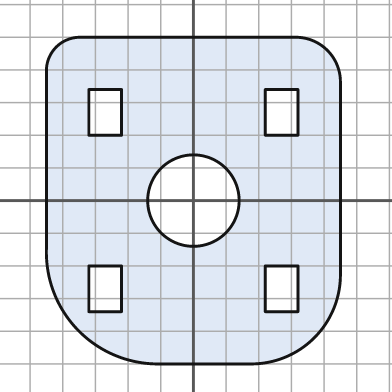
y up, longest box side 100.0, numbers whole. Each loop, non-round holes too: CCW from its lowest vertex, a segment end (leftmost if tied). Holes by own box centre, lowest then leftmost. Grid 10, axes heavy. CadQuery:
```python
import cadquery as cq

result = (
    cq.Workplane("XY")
    .moveTo(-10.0, -50.0)
    .lineTo(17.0, -50.0)
    .threePointArc((37.0, -42.0), (45.0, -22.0))
    .lineTo(45.0, 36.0)
    .threePointArc((41.0, 46.0), (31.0, 50.0))
    .lineTo(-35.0, 50.0)
    .threePointArc((-42.0, 47.0), (-45.0, 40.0))
    .lineTo(-45.0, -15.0)
    .threePointArc((-35.0, -40.0), (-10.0, -50.0))
    .close()
    .moveTo(-32.0, -34.0)
    .lineTo(-22.0, -34.0)
    .lineTo(-22.0, -20.0)
    .lineTo(-32.0, -20.0)
    .close()
    .moveTo(22.0, -34.0)
    .lineTo(32.0, -34.0)
    .lineTo(32.0, -20.0)
    .lineTo(22.0, -20.0)
    .close()
    .moveTo(0.0, 0.0)
    .circle(14.0)
    .moveTo(-32.0, 20.0)
    .lineTo(-22.0, 20.0)
    .lineTo(-22.0, 34.0)
    .lineTo(-32.0, 34.0)
    .close()
    .moveTo(22.0, 20.0)
    .lineTo(32.0, 20.0)
    .lineTo(32.0, 34.0)
    .lineTo(22.0, 34.0)
    .close()
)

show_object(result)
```